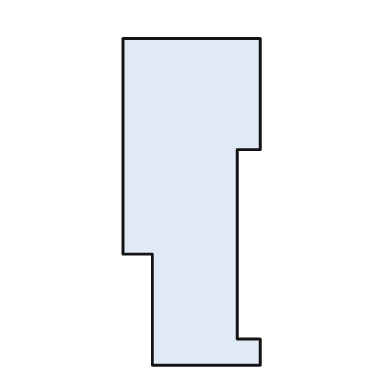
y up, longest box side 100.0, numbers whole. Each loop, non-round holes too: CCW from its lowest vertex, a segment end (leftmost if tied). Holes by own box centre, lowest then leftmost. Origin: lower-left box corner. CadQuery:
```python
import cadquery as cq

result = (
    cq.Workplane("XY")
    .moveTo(9.0, 0.0)
    .lineTo(42.0, 0.0)
    .lineTo(42.0, 8.0)
    .lineTo(35.0, 8.0)
    .lineTo(35.0, 66.0)
    .lineTo(42.0, 66.0)
    .lineTo(42.0, 100.0)
    .lineTo(0.0, 100.0)
    .lineTo(0.0, 34.0)
    .lineTo(9.0, 34.0)
    .close()
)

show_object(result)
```